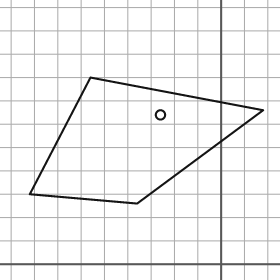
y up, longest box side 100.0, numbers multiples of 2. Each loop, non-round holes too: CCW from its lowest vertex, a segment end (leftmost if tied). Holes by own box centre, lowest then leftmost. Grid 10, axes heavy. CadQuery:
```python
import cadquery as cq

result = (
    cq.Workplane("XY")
    .moveTo(-36.0, 26.0)
    .lineTo(18.0, 66.0)
    .lineTo(-56.0, 80.0)
    .lineTo(-82.0, 30.0)
    .close()
    .moveTo(-26.0, 64.0)
    .circle(2.0)
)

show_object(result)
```